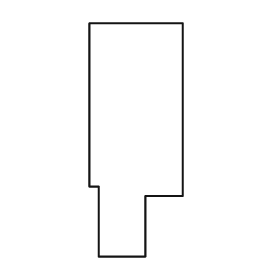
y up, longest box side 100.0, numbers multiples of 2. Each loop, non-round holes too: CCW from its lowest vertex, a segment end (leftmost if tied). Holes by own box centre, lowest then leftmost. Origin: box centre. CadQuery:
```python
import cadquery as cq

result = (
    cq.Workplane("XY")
    .moveTo(-16.0, -50.0)
    .lineTo(4.0, -50.0)
    .lineTo(4.0, -24.0)
    .lineTo(20.0, -24.0)
    .lineTo(20.0, 50.0)
    .lineTo(-20.0, 50.0)
    .lineTo(-20.0, -20.0)
    .lineTo(-16.0, -20.0)
    .close()
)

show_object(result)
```